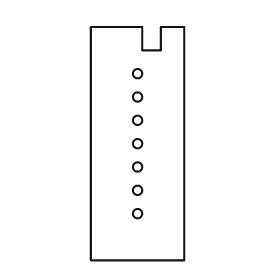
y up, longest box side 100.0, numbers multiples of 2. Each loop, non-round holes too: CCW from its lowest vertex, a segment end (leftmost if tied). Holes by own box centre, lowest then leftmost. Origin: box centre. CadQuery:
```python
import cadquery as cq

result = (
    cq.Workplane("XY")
    .moveTo(-20.0, -50.0)
    .lineTo(20.0, -50.0)
    .lineTo(20.0, 50.0)
    .lineTo(10.0, 50.0)
    .lineTo(10.0, 40.0)
    .lineTo(2.0, 40.0)
    .lineTo(2.0, 50.0)
    .lineTo(-20.0, 50.0)
    .close()
    .moveTo(0.0, -30.0)
    .circle(2.0)
    .moveTo(0.0, -20.0)
    .circle(2.0)
    .moveTo(0.0, -10.0)
    .circle(2.0)
    .moveTo(0.0, 0.0)
    .circle(2.0)
    .moveTo(0.0, 10.0)
    .circle(2.0)
    .moveTo(0.0, 20.0)
    .circle(2.0)
    .moveTo(0.0, 30.0)
    .circle(2.0)
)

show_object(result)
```